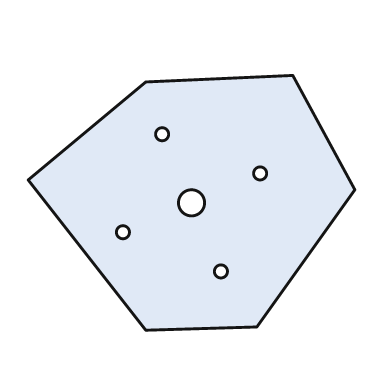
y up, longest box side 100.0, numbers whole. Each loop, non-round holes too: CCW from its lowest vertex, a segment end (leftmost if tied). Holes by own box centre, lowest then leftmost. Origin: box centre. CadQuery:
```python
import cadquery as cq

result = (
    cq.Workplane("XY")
    .moveTo(-14.0, -39.0)
    .lineTo(20.0, -38.0)
    .lineTo(50.0, 4.0)
    .lineTo(31.0, 39.0)
    .lineTo(-14.0, 37.0)
    .lineTo(-50.0, 7.0)
    .close()
    .moveTo(9.0, -21.0)
    .circle(2.0)
    .moveTo(-21.0, -9.0)
    .circle(2.0)
    .moveTo(0.0, 0.0)
    .circle(4.0)
    .moveTo(21.0, 9.0)
    .circle(2.0)
    .moveTo(-9.0, 21.0)
    .circle(2.0)
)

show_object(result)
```